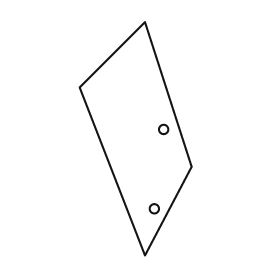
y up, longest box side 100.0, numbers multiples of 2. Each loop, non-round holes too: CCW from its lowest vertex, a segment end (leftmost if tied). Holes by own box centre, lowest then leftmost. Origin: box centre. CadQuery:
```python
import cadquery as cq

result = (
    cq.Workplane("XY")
    .moveTo(4.0, -50.0)
    .lineTo(24.0, -12.0)
    .lineTo(4.0, 50.0)
    .lineTo(-24.0, 22.0)
    .close()
    .moveTo(8.0, -30.0)
    .circle(2.0)
    .moveTo(12.0, 4.0)
    .circle(2.0)
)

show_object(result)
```